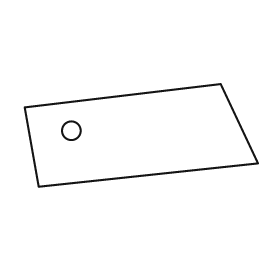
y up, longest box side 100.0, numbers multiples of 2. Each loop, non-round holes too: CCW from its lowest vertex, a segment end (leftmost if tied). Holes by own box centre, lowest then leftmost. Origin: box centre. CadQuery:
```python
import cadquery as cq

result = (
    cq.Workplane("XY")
    .moveTo(-44.0, -22.0)
    .lineTo(50.0, -12.0)
    .lineTo(34.0, 22.0)
    .lineTo(-50.0, 12.0)
    .close()
    .moveTo(-30.0, 2.0)
    .circle(4.0)
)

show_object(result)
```